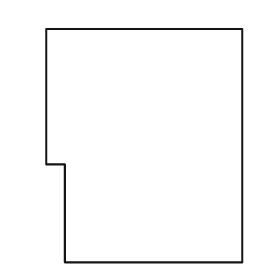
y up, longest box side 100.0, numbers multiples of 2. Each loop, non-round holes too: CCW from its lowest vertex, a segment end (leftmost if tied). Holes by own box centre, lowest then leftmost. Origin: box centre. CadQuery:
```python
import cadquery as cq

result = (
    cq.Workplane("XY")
    .moveTo(-34.0, -50.0)
    .lineTo(42.0, -50.0)
    .lineTo(42.0, 50.0)
    .lineTo(-42.0, 50.0)
    .lineTo(-42.0, -8.0)
    .lineTo(-34.0, -8.0)
    .close()
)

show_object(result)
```